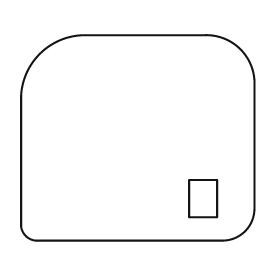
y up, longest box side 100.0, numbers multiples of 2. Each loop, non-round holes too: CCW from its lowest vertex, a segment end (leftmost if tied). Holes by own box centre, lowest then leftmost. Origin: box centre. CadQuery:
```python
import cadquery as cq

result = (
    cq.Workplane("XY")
    .moveTo(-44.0, -44.0)
    .lineTo(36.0, -44.0)
    .threePointArc((46.0, -40.0), (50.0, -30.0))
    .lineTo(50.0, 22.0)
    .threePointArc((44.0, 38.0), (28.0, 44.0))
    .lineTo(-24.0, 44.0)
    .threePointArc((-42.0, 36.0), (-50.0, 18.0))
    .lineTo(-50.0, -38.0)
    .threePointArc((-48.0, -42.0), (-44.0, -44.0))
    .close()
    .moveTo(22.0, -34.0)
    .lineTo(34.0, -34.0)
    .lineTo(34.0, -18.0)
    .lineTo(22.0, -18.0)
    .close()
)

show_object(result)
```